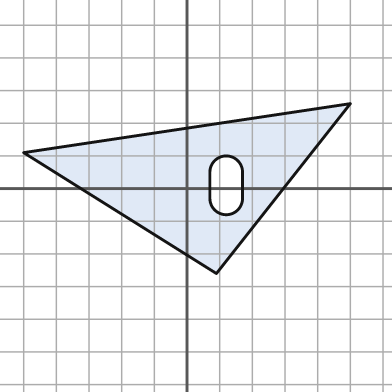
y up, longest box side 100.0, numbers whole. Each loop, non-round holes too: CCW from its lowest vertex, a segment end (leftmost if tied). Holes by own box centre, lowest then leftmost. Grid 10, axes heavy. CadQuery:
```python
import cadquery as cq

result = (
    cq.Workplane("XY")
    .moveTo(9.0, -26.0)
    .lineTo(50.0, 26.0)
    .lineTo(-50.0, 11.0)
    .close()
    .moveTo(7.0, -3.0)
    .threePointArc((12.0, -8.0), (17.0, -3.0))
    .lineTo(17.0, 5.0)
    .threePointArc((12.0, 10.0), (7.0, 5.0))
    .close()
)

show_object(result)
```